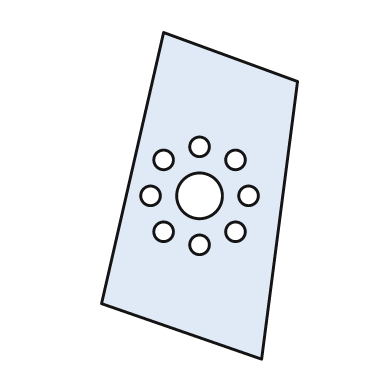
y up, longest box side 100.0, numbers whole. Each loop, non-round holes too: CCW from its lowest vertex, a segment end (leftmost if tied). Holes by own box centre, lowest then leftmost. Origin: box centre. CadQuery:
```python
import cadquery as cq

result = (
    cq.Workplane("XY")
    .moveTo(19.0, -50.0)
    .lineTo(30.0, 35.0)
    .lineTo(-11.0, 50.0)
    .lineTo(-30.0, -33.0)
    .close()
    .moveTo(0.0, -15.0)
    .circle(3.0)
    .moveTo(-11.0, -11.0)
    .circle(3.0)
    .moveTo(11.0, -11.0)
    .circle(3.0)
    .moveTo(-15.0, 0.0)
    .circle(3.0)
    .moveTo(0.0, 0.0)
    .circle(7.0)
    .moveTo(15.0, 0.0)
    .circle(3.0)
    .moveTo(-11.0, 11.0)
    .circle(3.0)
    .moveTo(11.0, 11.0)
    .circle(3.0)
    .moveTo(0.0, 15.0)
    .circle(3.0)
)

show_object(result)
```